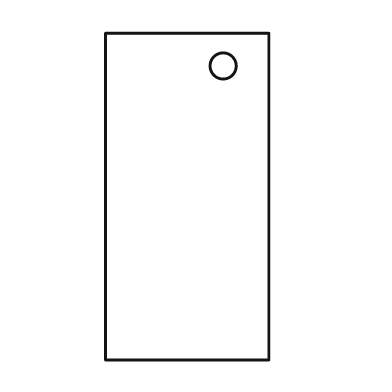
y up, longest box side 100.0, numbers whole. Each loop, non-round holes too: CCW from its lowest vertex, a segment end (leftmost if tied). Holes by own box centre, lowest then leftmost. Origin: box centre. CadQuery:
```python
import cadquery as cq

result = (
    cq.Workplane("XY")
    .moveTo(-25.0, -50.0)
    .lineTo(25.0, -50.0)
    .lineTo(25.0, 50.0)
    .lineTo(-25.0, 50.0)
    .close()
    .moveTo(11.0, 40.0)
    .circle(4.0)
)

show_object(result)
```